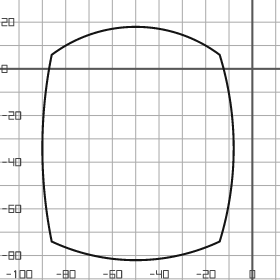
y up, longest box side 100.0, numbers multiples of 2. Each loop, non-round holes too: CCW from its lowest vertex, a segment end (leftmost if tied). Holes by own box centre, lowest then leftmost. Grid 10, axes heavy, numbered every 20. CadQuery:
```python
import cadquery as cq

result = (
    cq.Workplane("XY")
    .moveTo(-86.0, -74.0)
    .threePointArc((-50.0, -82.0), (-14.0, -74.0))
    .threePointArc((-8.0, -34.0), (-14.0, 6.0))
    .threePointArc((-50.0, 18.0), (-86.0, 6.0))
    .threePointArc((-90.0, -34.0), (-86.0, -74.0))
    .close()
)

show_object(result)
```